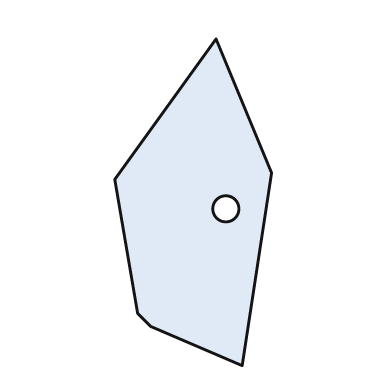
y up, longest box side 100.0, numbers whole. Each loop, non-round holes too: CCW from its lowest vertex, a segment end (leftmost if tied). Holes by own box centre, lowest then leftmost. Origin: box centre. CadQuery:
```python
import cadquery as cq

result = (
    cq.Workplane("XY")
    .moveTo(15.0, -50.0)
    .lineTo(24.0, 9.0)
    .lineTo(7.0, 50.0)
    .lineTo(-24.0, 7.0)
    .lineTo(-17.0, -34.0)
    .lineTo(-13.0, -38.0)
    .close()
    .moveTo(10.0, -2.0)
    .circle(4.0)
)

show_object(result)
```